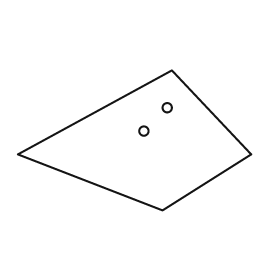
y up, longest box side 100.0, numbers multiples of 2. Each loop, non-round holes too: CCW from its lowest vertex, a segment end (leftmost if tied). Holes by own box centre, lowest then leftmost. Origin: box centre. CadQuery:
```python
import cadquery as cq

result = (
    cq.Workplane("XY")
    .moveTo(12.0, -30.0)
    .lineTo(50.0, -6.0)
    .lineTo(16.0, 30.0)
    .lineTo(-50.0, -6.0)
    .close()
    .moveTo(4.0, 4.0)
    .circle(2.0)
    .moveTo(14.0, 14.0)
    .circle(2.0)
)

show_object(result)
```